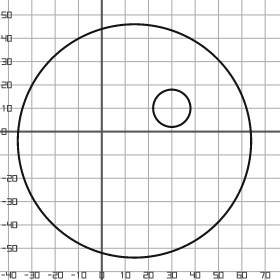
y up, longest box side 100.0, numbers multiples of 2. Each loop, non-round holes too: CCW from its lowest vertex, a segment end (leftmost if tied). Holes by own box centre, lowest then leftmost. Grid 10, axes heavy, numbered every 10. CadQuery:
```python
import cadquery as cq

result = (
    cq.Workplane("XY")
    .moveTo(14.0, -4.0)
    .circle(50.0)
    .moveTo(30.0, 10.0)
    .circle(8.0)
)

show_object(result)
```